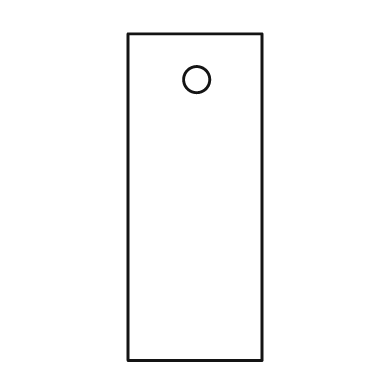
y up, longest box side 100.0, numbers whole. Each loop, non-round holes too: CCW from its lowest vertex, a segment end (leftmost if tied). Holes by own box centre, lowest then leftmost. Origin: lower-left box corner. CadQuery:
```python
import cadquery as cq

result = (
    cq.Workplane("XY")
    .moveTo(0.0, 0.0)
    .lineTo(41.0, 0.0)
    .lineTo(41.0, 100.0)
    .lineTo(0.0, 100.0)
    .close()
    .moveTo(21.0, 86.0)
    .circle(4.0)
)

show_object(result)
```